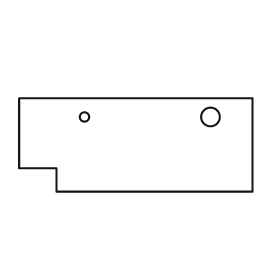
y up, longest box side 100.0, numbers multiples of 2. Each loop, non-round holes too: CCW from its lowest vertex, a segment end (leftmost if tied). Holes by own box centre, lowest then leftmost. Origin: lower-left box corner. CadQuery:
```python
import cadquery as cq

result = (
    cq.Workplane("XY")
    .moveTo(16.0, 0.0)
    .lineTo(100.0, 0.0)
    .lineTo(100.0, 40.0)
    .lineTo(0.0, 40.0)
    .lineTo(0.0, 10.0)
    .lineTo(16.0, 10.0)
    .close()
    .moveTo(28.0, 32.0)
    .circle(2.0)
    .moveTo(82.0, 32.0)
    .circle(4.0)
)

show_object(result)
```